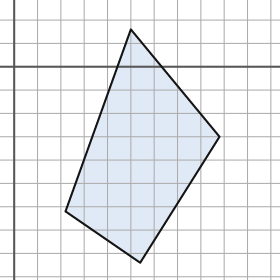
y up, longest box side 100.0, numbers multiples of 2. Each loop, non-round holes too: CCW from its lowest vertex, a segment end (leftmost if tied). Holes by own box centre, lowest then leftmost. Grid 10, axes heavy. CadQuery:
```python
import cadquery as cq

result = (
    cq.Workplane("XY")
    .moveTo(54.0, -84.0)
    .lineTo(88.0, -30.0)
    .lineTo(50.0, 16.0)
    .lineTo(22.0, -62.0)
    .close()
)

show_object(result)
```